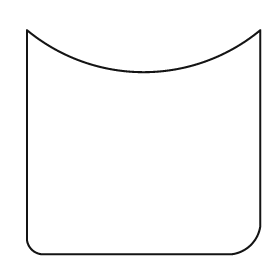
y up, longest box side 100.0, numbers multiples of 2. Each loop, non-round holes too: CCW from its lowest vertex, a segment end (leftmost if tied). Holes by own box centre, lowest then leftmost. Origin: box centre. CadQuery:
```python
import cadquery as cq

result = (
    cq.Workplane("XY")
    .moveTo(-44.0, -48.0)
    .lineTo(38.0, -48.0)
    .threePointArc((46.0, -44.0), (50.0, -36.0))
    .lineTo(50.0, 48.0)
    .threePointArc((0.0, 30.0), (-50.0, 48.0))
    .lineTo(-50.0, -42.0)
    .threePointArc((-48.0, -46.0), (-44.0, -48.0))
    .close()
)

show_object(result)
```